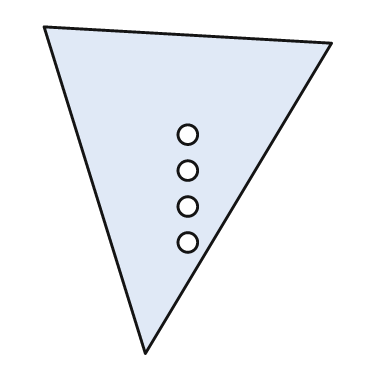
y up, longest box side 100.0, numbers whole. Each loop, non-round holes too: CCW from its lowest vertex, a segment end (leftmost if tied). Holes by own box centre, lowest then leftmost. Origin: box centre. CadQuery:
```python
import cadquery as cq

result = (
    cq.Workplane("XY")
    .moveTo(-13.0, -50.0)
    .lineTo(44.0, 45.0)
    .lineTo(-44.0, 50.0)
    .close()
    .moveTo(0.0, -16.0)
    .circle(3.0)
    .moveTo(0.0, -5.0)
    .circle(3.0)
    .moveTo(0.0, 6.0)
    .circle(3.0)
    .moveTo(0.0, 17.0)
    .circle(3.0)
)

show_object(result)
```